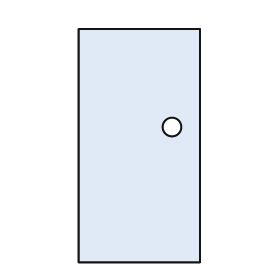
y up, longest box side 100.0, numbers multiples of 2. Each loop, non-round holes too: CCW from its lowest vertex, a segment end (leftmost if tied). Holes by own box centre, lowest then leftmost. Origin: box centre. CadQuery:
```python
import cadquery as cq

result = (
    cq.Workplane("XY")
    .moveTo(-26.0, -50.0)
    .lineTo(26.0, -50.0)
    .lineTo(26.0, 50.0)
    .lineTo(-26.0, 50.0)
    .close()
    .moveTo(14.0, 8.0)
    .circle(4.0)
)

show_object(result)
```